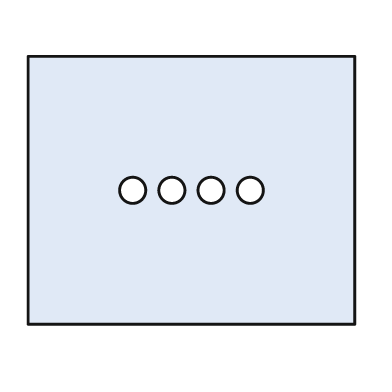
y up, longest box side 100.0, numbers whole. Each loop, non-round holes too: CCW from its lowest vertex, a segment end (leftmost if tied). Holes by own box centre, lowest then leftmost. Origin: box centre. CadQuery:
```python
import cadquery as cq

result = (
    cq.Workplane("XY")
    .moveTo(-50.0, -41.0)
    .lineTo(50.0, -41.0)
    .lineTo(50.0, 41.0)
    .lineTo(-50.0, 41.0)
    .close()
    .moveTo(-18.0, 0.0)
    .circle(4.0)
    .moveTo(-6.0, 0.0)
    .circle(4.0)
    .moveTo(6.0, 0.0)
    .circle(4.0)
    .moveTo(18.0, 0.0)
    .circle(4.0)
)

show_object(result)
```